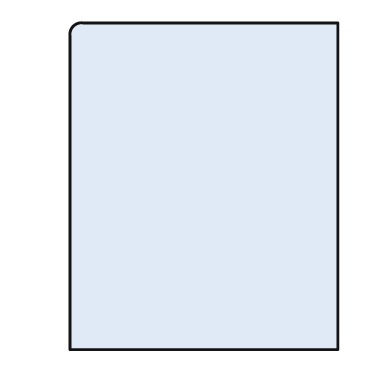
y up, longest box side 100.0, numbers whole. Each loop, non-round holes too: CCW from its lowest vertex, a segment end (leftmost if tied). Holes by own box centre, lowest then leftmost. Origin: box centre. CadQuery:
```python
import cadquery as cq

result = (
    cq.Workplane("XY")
    .moveTo(-41.0, -50.0)
    .lineTo(41.0, -50.0)
    .lineTo(41.0, 50.0)
    .lineTo(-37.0, 50.0)
    .threePointArc((-40.0, 49.0), (-41.0, 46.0))
    .close()
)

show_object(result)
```